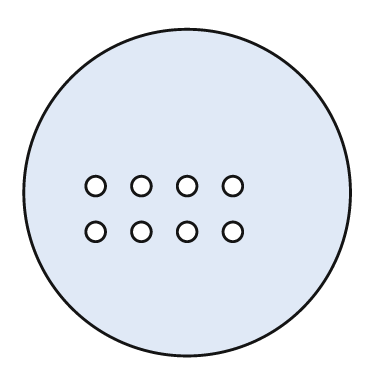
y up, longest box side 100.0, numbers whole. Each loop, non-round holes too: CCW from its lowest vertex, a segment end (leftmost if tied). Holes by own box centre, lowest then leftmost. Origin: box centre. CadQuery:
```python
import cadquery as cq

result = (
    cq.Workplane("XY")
    .moveTo(0.0, 0.0)
    .circle(50.0)
    .moveTo(-28.0, -12.0)
    .circle(3.0)
    .moveTo(-14.0, -12.0)
    .circle(3.0)
    .moveTo(0.0, -12.0)
    .circle(3.0)
    .moveTo(14.0, -12.0)
    .circle(3.0)
    .moveTo(-28.0, 2.0)
    .circle(3.0)
    .moveTo(-14.0, 2.0)
    .circle(3.0)
    .moveTo(0.0, 2.0)
    .circle(3.0)
    .moveTo(14.0, 2.0)
    .circle(3.0)
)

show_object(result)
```